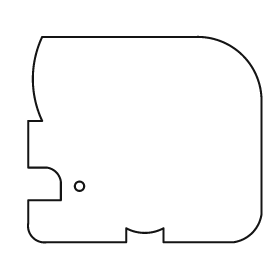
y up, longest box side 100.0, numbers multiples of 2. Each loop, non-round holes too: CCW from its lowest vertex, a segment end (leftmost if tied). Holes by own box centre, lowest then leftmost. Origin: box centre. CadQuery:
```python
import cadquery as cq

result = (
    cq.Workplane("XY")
    .moveTo(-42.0, -44.0)
    .lineTo(-8.0, -44.0)
    .lineTo(-8.0, -38.0)
    .threePointArc((0.0, -40.0), (8.0, -38.0))
    .lineTo(8.0, -44.0)
    .lineTo(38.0, -44.0)
    .threePointArc((46.0, -40.0), (50.0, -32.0))
    .lineTo(50.0, 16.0)
    .threePointArc((42.0, 36.0), (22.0, 44.0))
    .lineTo(-44.0, 44.0)
    .threePointArc((-48.0, 26.0), (-44.0, 8.0))
    .lineTo(-50.0, 8.0)
    .lineTo(-50.0, -12.0)
    .lineTo(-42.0, -12.0)
    .threePointArc((-38.0, -14.0), (-36.0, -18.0))
    .lineTo(-36.0, -26.0)
    .lineTo(-50.0, -26.0)
    .lineTo(-50.0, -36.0)
    .threePointArc((-48.0, -42.0), (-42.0, -44.0))
    .close()
    .moveTo(-28.0, -20.0)
    .circle(2.0)
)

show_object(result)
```